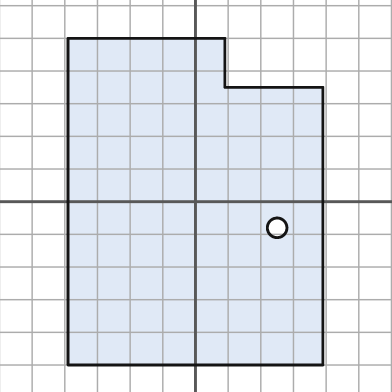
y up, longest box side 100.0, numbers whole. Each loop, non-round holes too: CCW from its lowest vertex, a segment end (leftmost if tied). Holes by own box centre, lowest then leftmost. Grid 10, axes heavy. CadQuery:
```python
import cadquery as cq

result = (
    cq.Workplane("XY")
    .moveTo(-39.0, -50.0)
    .lineTo(39.0, -50.0)
    .lineTo(39.0, 35.0)
    .lineTo(9.0, 35.0)
    .lineTo(9.0, 50.0)
    .lineTo(-39.0, 50.0)
    .close()
    .moveTo(25.0, -8.0)
    .circle(3.0)
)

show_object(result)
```